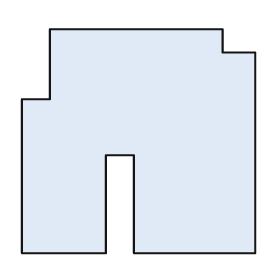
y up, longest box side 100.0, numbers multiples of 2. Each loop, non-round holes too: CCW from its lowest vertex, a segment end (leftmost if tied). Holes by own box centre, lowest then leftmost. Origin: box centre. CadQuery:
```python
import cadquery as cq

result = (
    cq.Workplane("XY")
    .moveTo(-50.0, -48.0)
    .lineTo(-14.0, -48.0)
    .lineTo(-14.0, -6.0)
    .lineTo(-2.0, -6.0)
    .lineTo(-2.0, -48.0)
    .lineTo(50.0, -48.0)
    .lineTo(50.0, 38.0)
    .lineTo(36.0, 38.0)
    .lineTo(36.0, 48.0)
    .lineTo(-38.0, 48.0)
    .lineTo(-38.0, 18.0)
    .lineTo(-50.0, 18.0)
    .close()
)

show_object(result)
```